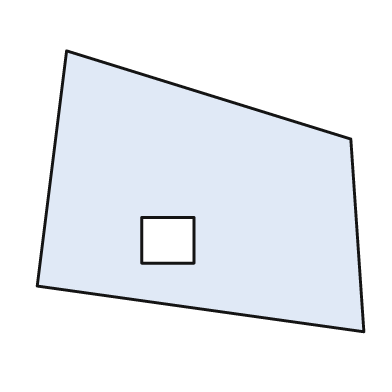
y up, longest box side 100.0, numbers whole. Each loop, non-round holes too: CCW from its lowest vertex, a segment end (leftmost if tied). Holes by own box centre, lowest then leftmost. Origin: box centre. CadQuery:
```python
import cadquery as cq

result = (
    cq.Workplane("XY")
    .moveTo(50.0, -43.0)
    .lineTo(46.0, 16.0)
    .lineTo(-41.0, 43.0)
    .lineTo(-50.0, -29.0)
    .close()
    .moveTo(-18.0, -22.0)
    .lineTo(-2.0, -22.0)
    .lineTo(-2.0, -8.0)
    .lineTo(-18.0, -8.0)
    .close()
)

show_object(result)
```